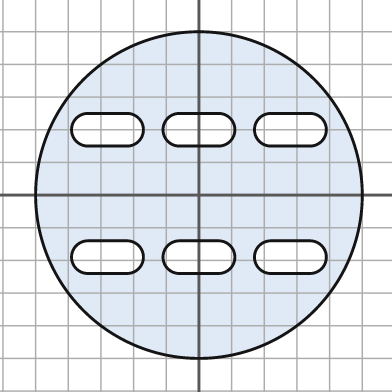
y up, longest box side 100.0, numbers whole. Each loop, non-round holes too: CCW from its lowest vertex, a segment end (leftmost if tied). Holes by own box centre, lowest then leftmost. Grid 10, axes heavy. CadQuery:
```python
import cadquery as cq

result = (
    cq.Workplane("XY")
    .moveTo(0.0, 0.0)
    .circle(50.0)
    .moveTo(-34.0, -24.0)
    .lineTo(-22.0, -24.0)
    .threePointArc((-17.0, -19.0), (-22.0, -14.0))
    .lineTo(-34.0, -14.0)
    .threePointArc((-39.0, -19.0), (-34.0, -24.0))
    .close()
    .moveTo(-6.0, -24.0)
    .lineTo(6.0, -24.0)
    .threePointArc((11.0, -19.0), (6.0, -14.0))
    .lineTo(-6.0, -14.0)
    .threePointArc((-11.0, -19.0), (-6.0, -24.0))
    .close()
    .moveTo(22.0, -24.0)
    .lineTo(34.0, -24.0)
    .threePointArc((39.0, -19.0), (34.0, -14.0))
    .lineTo(22.0, -14.0)
    .threePointArc((17.0, -19.0), (22.0, -24.0))
    .close()
    .moveTo(-34.0, 15.0)
    .lineTo(-22.0, 15.0)
    .threePointArc((-17.0, 20.0), (-22.0, 25.0))
    .lineTo(-34.0, 25.0)
    .threePointArc((-39.0, 20.0), (-34.0, 15.0))
    .close()
    .moveTo(-6.0, 15.0)
    .lineTo(6.0, 15.0)
    .threePointArc((11.0, 20.0), (6.0, 25.0))
    .lineTo(-6.0, 25.0)
    .threePointArc((-11.0, 20.0), (-6.0, 15.0))
    .close()
    .moveTo(22.0, 15.0)
    .lineTo(34.0, 15.0)
    .threePointArc((39.0, 20.0), (34.0, 25.0))
    .lineTo(22.0, 25.0)
    .threePointArc((17.0, 20.0), (22.0, 15.0))
    .close()
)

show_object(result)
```